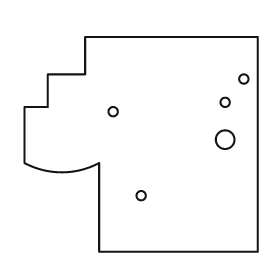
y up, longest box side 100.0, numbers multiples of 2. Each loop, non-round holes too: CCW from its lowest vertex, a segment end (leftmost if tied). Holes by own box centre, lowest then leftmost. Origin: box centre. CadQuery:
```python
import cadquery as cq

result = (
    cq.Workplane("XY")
    .moveTo(-18.0, -46.0)
    .lineTo(50.0, -46.0)
    .lineTo(50.0, 46.0)
    .lineTo(-24.0, 46.0)
    .lineTo(-24.0, 30.0)
    .lineTo(-40.0, 30.0)
    .lineTo(-40.0, 16.0)
    .lineTo(-50.0, 16.0)
    .lineTo(-50.0, -8.0)
    .threePointArc((-34.0, -12.0), (-18.0, -8.0))
    .close()
    .moveTo(0.0, -22.0)
    .circle(2.0)
    .moveTo(36.0, 2.0)
    .circle(4.0)
    .moveTo(-12.0, 14.0)
    .circle(2.0)
    .moveTo(36.0, 18.0)
    .circle(2.0)
    .moveTo(44.0, 28.0)
    .circle(2.0)
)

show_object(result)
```